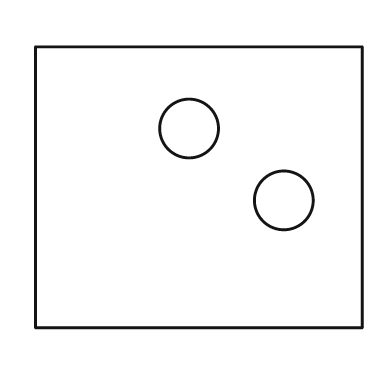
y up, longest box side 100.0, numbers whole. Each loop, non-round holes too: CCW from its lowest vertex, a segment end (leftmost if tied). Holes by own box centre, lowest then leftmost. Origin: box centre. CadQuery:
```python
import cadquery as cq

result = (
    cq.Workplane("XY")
    .moveTo(-50.0, -43.0)
    .lineTo(50.0, -43.0)
    .lineTo(50.0, 43.0)
    .lineTo(-50.0, 43.0)
    .close()
    .moveTo(26.0, -4.0)
    .circle(9.0)
    .moveTo(-3.0, 18.0)
    .circle(9.0)
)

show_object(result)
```